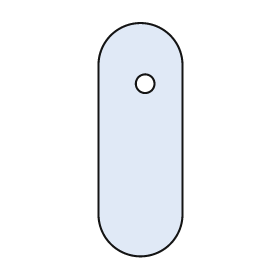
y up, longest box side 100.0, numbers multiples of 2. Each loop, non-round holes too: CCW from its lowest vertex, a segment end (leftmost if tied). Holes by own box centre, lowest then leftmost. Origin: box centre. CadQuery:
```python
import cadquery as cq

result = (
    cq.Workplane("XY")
    .moveTo(-18.0, -32.0)
    .threePointArc((0.0, -50.0), (18.0, -32.0))
    .lineTo(18.0, 32.0)
    .threePointArc((0.0, 50.0), (-18.0, 32.0))
    .close()
    .moveTo(2.0, 24.0)
    .circle(4.0)
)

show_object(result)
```